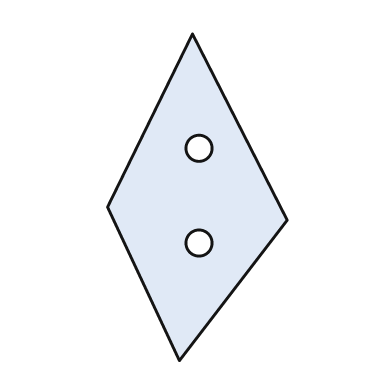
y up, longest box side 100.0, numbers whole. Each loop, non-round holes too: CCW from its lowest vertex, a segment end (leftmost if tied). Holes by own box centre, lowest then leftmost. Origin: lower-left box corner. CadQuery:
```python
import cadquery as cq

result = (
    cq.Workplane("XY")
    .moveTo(22.0, 0.0)
    .lineTo(55.0, 43.0)
    .lineTo(26.0, 100.0)
    .lineTo(0.0, 47.0)
    .close()
    .moveTo(28.0, 36.0)
    .circle(4.0)
    .moveTo(28.0, 65.0)
    .circle(4.0)
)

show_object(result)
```